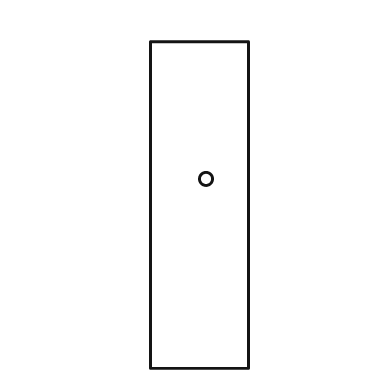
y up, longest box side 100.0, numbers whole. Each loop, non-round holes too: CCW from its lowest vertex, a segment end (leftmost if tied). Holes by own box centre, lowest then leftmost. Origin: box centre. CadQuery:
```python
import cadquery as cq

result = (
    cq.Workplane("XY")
    .moveTo(-15.0, -50.0)
    .lineTo(15.0, -50.0)
    .lineTo(15.0, 50.0)
    .lineTo(-15.0, 50.0)
    .close()
    .moveTo(2.0, 8.0)
    .circle(2.0)
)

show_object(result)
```